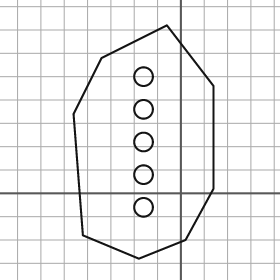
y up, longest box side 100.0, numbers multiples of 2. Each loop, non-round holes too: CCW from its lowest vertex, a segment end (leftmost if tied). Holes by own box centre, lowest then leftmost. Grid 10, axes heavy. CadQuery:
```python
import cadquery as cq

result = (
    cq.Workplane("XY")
    .moveTo(-18.0, -28.0)
    .lineTo(2.0, -20.0)
    .lineTo(14.0, 2.0)
    .lineTo(14.0, 46.0)
    .lineTo(-6.0, 72.0)
    .lineTo(-34.0, 58.0)
    .lineTo(-46.0, 34.0)
    .lineTo(-42.0, -18.0)
    .close()
    .moveTo(-16.0, -6.0)
    .circle(4.0)
    .moveTo(-16.0, 8.0)
    .circle(4.0)
    .moveTo(-16.0, 22.0)
    .circle(4.0)
    .moveTo(-16.0, 36.0)
    .circle(4.0)
    .moveTo(-16.0, 50.0)
    .circle(4.0)
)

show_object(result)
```